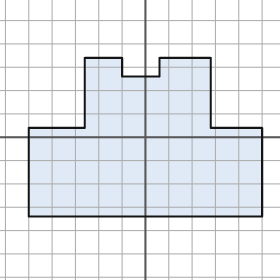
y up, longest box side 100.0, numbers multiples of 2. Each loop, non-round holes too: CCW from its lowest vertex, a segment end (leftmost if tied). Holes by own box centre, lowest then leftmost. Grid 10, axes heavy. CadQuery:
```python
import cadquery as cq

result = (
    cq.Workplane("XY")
    .moveTo(-50.0, -34.0)
    .lineTo(50.0, -34.0)
    .lineTo(50.0, 4.0)
    .lineTo(28.0, 4.0)
    .lineTo(28.0, 34.0)
    .lineTo(6.0, 34.0)
    .lineTo(6.0, 26.0)
    .lineTo(-10.0, 26.0)
    .lineTo(-10.0, 34.0)
    .lineTo(-26.0, 34.0)
    .lineTo(-26.0, 4.0)
    .lineTo(-50.0, 4.0)
    .close()
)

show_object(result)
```